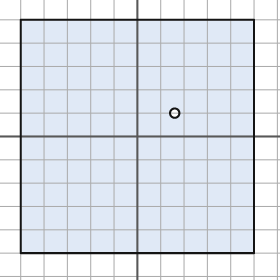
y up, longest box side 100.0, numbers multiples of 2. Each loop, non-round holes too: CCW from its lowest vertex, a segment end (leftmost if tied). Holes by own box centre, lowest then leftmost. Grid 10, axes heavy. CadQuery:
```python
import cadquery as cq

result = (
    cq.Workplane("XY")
    .moveTo(-50.0, -50.0)
    .lineTo(50.0, -50.0)
    .lineTo(50.0, 50.0)
    .lineTo(-50.0, 50.0)
    .close()
    .moveTo(16.0, 10.0)
    .circle(2.0)
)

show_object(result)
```